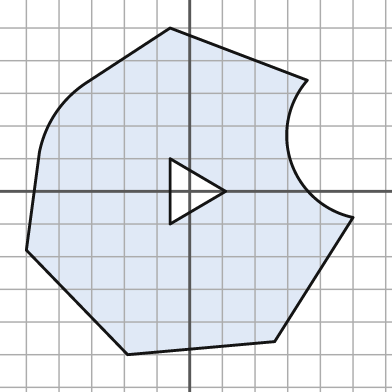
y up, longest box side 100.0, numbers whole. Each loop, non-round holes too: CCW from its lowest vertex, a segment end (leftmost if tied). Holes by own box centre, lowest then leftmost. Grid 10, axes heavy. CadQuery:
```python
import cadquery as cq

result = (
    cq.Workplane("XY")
    .moveTo(-19.0, -50.0)
    .lineTo(26.0, -46.0)
    .lineTo(50.0, -8.0)
    .threePointArc((31.0, 9.0), (36.0, 34.0))
    .lineTo(-6.0, 50.0)
    .lineTo(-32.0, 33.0)
    .threePointArc((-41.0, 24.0), (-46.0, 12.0))
    .lineTo(-50.0, -18.0)
    .close()
    .moveTo(-6.0, -10.0)
    .lineTo(11.0, 0.0)
    .lineTo(-6.0, 10.0)
    .close()
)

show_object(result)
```